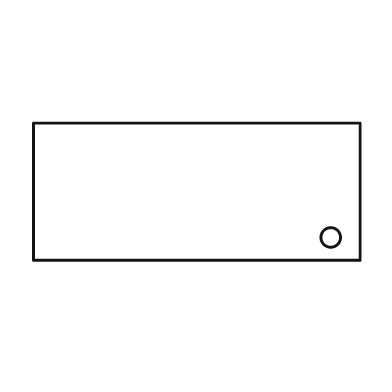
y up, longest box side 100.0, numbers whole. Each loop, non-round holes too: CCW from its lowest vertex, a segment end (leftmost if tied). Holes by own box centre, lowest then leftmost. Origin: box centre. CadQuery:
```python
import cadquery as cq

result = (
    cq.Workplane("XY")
    .moveTo(-50.0, -21.0)
    .lineTo(50.0, -21.0)
    .lineTo(50.0, 21.0)
    .lineTo(-50.0, 21.0)
    .close()
    .moveTo(41.0, -14.0)
    .circle(3.0)
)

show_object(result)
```